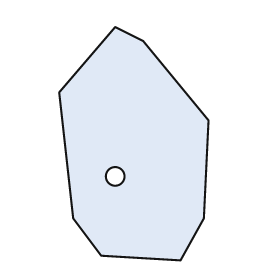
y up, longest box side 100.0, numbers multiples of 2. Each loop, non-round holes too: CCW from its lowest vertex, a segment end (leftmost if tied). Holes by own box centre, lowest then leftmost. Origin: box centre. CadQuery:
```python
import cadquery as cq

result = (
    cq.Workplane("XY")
    .moveTo(20.0, -50.0)
    .lineTo(30.0, -32.0)
    .lineTo(32.0, 10.0)
    .lineTo(4.0, 44.0)
    .lineTo(-8.0, 50.0)
    .lineTo(-32.0, 22.0)
    .lineTo(-26.0, -32.0)
    .lineTo(-14.0, -48.0)
    .close()
    .moveTo(-8.0, -14.0)
    .circle(4.0)
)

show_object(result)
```